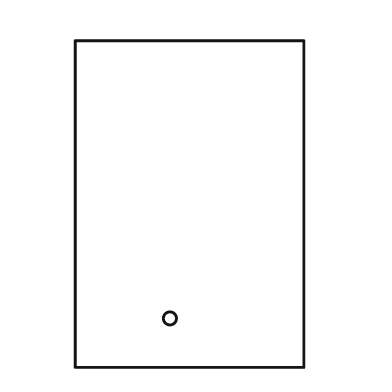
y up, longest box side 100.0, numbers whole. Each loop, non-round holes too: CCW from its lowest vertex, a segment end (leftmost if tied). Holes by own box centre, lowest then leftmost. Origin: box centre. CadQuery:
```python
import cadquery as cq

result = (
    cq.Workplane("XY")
    .moveTo(-35.0, -50.0)
    .lineTo(35.0, -50.0)
    .lineTo(35.0, 50.0)
    .lineTo(-35.0, 50.0)
    .close()
    .moveTo(-6.0, -35.0)
    .circle(2.0)
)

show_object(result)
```